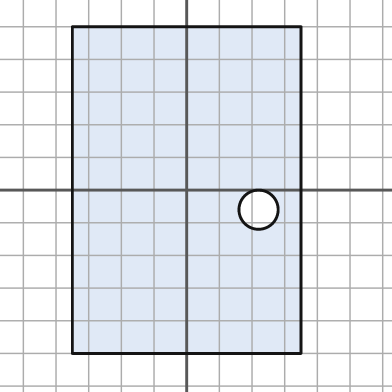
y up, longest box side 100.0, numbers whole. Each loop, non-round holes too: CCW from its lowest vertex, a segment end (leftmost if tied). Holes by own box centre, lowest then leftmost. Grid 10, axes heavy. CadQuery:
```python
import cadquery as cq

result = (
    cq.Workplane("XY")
    .moveTo(-35.0, -50.0)
    .lineTo(35.0, -50.0)
    .lineTo(35.0, 50.0)
    .lineTo(-35.0, 50.0)
    .close()
    .moveTo(22.0, -6.0)
    .circle(6.0)
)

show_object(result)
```